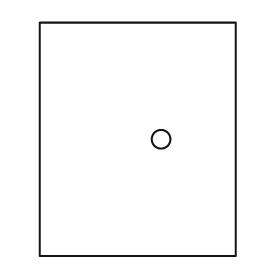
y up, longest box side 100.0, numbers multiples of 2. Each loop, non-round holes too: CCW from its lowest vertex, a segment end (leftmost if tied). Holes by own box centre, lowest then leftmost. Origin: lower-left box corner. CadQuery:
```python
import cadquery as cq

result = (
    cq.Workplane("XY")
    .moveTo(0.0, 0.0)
    .lineTo(84.0, 0.0)
    .lineTo(84.0, 100.0)
    .lineTo(0.0, 100.0)
    .close()
    .moveTo(52.0, 50.0)
    .circle(4.0)
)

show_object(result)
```